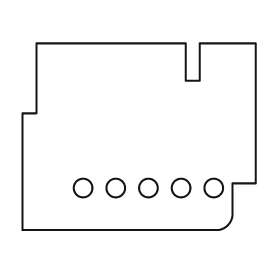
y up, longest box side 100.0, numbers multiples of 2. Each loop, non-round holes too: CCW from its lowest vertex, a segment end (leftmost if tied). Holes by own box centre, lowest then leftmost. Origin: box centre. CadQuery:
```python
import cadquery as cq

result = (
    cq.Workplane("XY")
    .moveTo(-50.0, -40.0)
    .lineTo(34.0, -40.0)
    .threePointArc((38.0, -38.0), (40.0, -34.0))
    .lineTo(40.0, -20.0)
    .lineTo(50.0, -20.0)
    .lineTo(50.0, 40.0)
    .lineTo(26.0, 40.0)
    .lineTo(26.0, 24.0)
    .lineTo(20.0, 24.0)
    .lineTo(20.0, 40.0)
    .lineTo(-44.0, 40.0)
    .lineTo(-44.0, 10.0)
    .lineTo(-50.0, 10.0)
    .close()
    .moveTo(-24.0, -22.0)
    .circle(4.0)
    .moveTo(-10.0, -22.0)
    .circle(4.0)
    .moveTo(4.0, -22.0)
    .circle(4.0)
    .moveTo(18.0, -22.0)
    .circle(4.0)
    .moveTo(32.0, -22.0)
    .circle(4.0)
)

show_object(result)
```